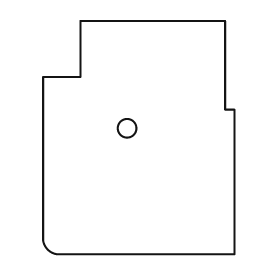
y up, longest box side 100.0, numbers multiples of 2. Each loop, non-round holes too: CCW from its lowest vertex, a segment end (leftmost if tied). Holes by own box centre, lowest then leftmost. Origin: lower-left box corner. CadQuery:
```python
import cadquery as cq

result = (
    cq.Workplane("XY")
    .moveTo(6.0, 0.0)
    .lineTo(82.0, 0.0)
    .lineTo(82.0, 62.0)
    .lineTo(78.0, 62.0)
    .lineTo(78.0, 100.0)
    .lineTo(16.0, 100.0)
    .lineTo(16.0, 76.0)
    .lineTo(0.0, 76.0)
    .lineTo(0.0, 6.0)
    .threePointArc((2.0, 2.0), (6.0, 0.0))
    .close()
    .moveTo(36.0, 54.0)
    .circle(4.0)
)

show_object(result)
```